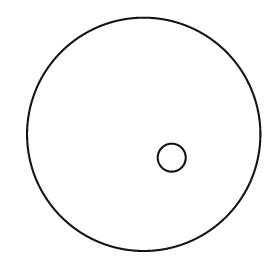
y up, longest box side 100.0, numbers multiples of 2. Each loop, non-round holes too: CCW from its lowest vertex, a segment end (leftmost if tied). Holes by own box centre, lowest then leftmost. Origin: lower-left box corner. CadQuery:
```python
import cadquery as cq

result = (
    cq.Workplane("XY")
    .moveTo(50.0, 50.0)
    .circle(50.0)
    .moveTo(62.0, 40.0)
    .circle(6.0)
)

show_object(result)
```